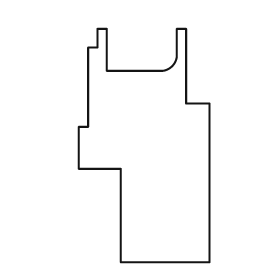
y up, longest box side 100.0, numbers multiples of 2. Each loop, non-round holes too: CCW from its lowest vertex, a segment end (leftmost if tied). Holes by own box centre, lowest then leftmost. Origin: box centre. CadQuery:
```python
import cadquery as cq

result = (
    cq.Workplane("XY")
    .moveTo(-10.0, -50.0)
    .lineTo(28.0, -50.0)
    .lineTo(28.0, 18.0)
    .lineTo(18.0, 18.0)
    .lineTo(18.0, 50.0)
    .lineTo(14.0, 50.0)
    .lineTo(14.0, 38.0)
    .threePointArc((12.0, 34.0), (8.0, 32.0))
    .lineTo(-16.0, 32.0)
    .lineTo(-16.0, 50.0)
    .lineTo(-20.0, 50.0)
    .lineTo(-20.0, 42.0)
    .lineTo(-24.0, 42.0)
    .lineTo(-24.0, 8.0)
    .lineTo(-28.0, 8.0)
    .lineTo(-28.0, -10.0)
    .lineTo(-10.0, -10.0)
    .close()
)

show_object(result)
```